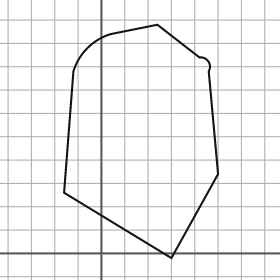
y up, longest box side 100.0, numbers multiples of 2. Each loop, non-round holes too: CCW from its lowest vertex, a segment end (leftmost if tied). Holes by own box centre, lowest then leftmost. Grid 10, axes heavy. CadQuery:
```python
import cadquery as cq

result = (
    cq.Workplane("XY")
    .moveTo(30.0, -2.0)
    .lineTo(50.0, 34.0)
    .lineTo(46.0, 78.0)
    .threePointArc((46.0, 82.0), (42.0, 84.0))
    .lineTo(24.0, 98.0)
    .lineTo(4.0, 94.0)
    .threePointArc((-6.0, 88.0), (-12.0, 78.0))
    .lineTo(-16.0, 26.0)
    .close()
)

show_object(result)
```